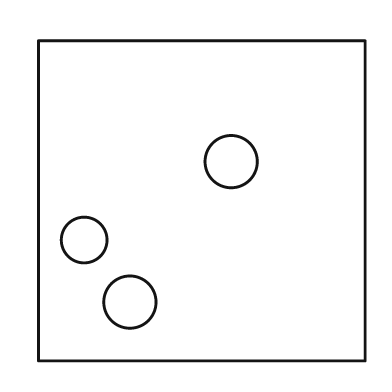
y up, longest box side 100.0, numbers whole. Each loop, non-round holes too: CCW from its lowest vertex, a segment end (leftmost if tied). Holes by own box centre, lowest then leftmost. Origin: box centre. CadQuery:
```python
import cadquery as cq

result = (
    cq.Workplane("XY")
    .moveTo(-50.0, -49.0)
    .lineTo(50.0, -49.0)
    .lineTo(50.0, 49.0)
    .lineTo(-50.0, 49.0)
    .close()
    .moveTo(-22.0, -31.0)
    .circle(8.0)
    .moveTo(-36.0, -12.0)
    .circle(7.0)
    .moveTo(9.0, 12.0)
    .circle(8.0)
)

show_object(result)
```